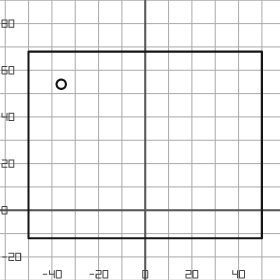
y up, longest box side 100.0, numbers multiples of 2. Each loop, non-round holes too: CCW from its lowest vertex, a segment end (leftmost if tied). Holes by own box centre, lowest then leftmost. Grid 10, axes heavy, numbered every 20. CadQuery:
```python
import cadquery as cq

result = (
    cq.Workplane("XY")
    .moveTo(-50.0, -12.0)
    .lineTo(50.0, -12.0)
    .lineTo(50.0, 68.0)
    .lineTo(-50.0, 68.0)
    .close()
    .moveTo(-36.0, 54.0)
    .circle(2.0)
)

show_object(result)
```